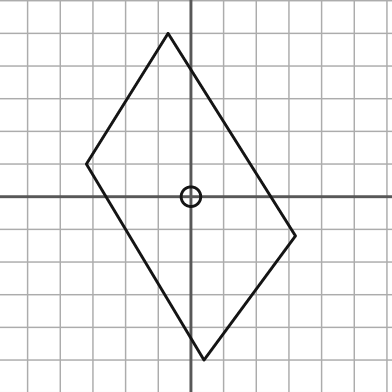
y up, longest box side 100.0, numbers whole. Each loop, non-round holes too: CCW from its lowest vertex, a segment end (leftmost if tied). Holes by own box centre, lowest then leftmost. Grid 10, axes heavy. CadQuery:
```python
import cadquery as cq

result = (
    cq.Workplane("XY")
    .moveTo(4.0, -50.0)
    .lineTo(32.0, -12.0)
    .lineTo(-7.0, 50.0)
    .lineTo(-32.0, 10.0)
    .close()
    .moveTo(0.0, 0.0)
    .circle(3.0)
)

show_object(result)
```